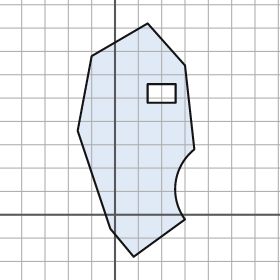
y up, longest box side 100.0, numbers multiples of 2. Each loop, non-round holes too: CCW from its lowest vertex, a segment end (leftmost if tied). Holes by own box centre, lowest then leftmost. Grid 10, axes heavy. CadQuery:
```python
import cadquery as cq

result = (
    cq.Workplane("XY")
    .moveTo(8.0, -18.0)
    .lineTo(30.0, -2.0)
    .threePointArc((26.0, 14.0), (34.0, 28.0))
    .lineTo(30.0, 64.0)
    .lineTo(14.0, 82.0)
    .lineTo(-10.0, 68.0)
    .lineTo(-16.0, 36.0)
    .lineTo(-2.0, -6.0)
    .close()
    .moveTo(14.0, 48.0)
    .lineTo(26.0, 48.0)
    .lineTo(26.0, 56.0)
    .lineTo(14.0, 56.0)
    .close()
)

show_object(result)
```